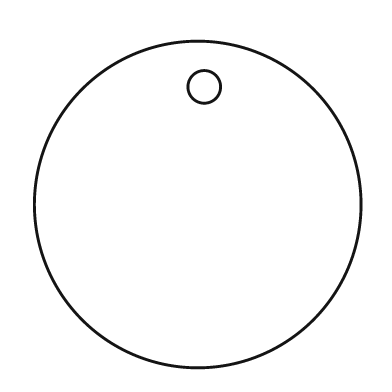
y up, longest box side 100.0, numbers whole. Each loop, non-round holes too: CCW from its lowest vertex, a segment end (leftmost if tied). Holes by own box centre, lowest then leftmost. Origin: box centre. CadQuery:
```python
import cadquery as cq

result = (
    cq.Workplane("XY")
    .moveTo(0.0, 0.0)
    .circle(50.0)
    .moveTo(2.0, 36.0)
    .circle(5.0)
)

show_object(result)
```